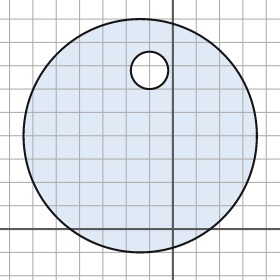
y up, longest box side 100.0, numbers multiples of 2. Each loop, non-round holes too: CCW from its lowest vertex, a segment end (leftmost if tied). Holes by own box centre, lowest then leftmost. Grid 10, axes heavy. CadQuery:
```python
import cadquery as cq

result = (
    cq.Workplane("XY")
    .moveTo(-14.0, 40.0)
    .circle(50.0)
    .moveTo(-10.0, 68.0)
    .circle(8.0)
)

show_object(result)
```